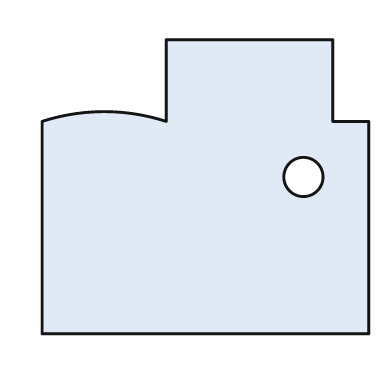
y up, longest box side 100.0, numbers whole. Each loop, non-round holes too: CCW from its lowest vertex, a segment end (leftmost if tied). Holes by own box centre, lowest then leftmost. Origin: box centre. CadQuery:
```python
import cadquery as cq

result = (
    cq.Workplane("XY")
    .moveTo(-50.0, -45.0)
    .lineTo(50.0, -45.0)
    .lineTo(50.0, 20.0)
    .lineTo(39.0, 20.0)
    .lineTo(39.0, 45.0)
    .lineTo(-12.0, 45.0)
    .lineTo(-12.0, 20.0)
    .threePointArc((-31.0, 23.0), (-50.0, 20.0))
    .close()
    .moveTo(30.0, 3.0)
    .circle(6.0)
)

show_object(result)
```